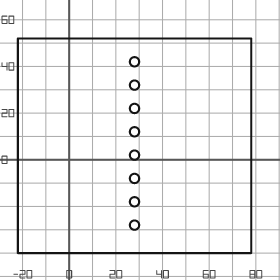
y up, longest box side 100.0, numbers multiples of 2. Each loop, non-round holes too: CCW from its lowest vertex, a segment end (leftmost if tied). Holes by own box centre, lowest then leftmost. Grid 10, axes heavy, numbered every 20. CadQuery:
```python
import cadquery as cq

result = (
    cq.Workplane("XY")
    .moveTo(-22.0, -40.0)
    .lineTo(78.0, -40.0)
    .lineTo(78.0, 52.0)
    .lineTo(-22.0, 52.0)
    .close()
    .moveTo(28.0, -28.0)
    .circle(2.0)
    .moveTo(28.0, -18.0)
    .circle(2.0)
    .moveTo(28.0, -8.0)
    .circle(2.0)
    .moveTo(28.0, 2.0)
    .circle(2.0)
    .moveTo(28.0, 12.0)
    .circle(2.0)
    .moveTo(28.0, 22.0)
    .circle(2.0)
    .moveTo(28.0, 32.0)
    .circle(2.0)
    .moveTo(28.0, 42.0)
    .circle(2.0)
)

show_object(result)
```